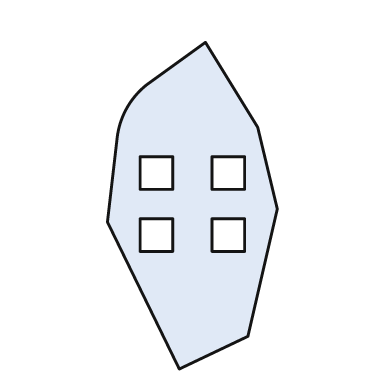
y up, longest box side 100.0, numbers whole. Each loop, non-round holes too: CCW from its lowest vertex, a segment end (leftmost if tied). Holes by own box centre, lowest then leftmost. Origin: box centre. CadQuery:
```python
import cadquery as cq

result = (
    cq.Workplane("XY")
    .moveTo(-4.0, -50.0)
    .lineTo(17.0, -40.0)
    .lineTo(26.0, -1.0)
    .lineTo(20.0, 24.0)
    .lineTo(4.0, 50.0)
    .lineTo(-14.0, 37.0)
    .threePointArc((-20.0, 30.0), (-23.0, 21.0))
    .lineTo(-26.0, -5.0)
    .close()
    .moveTo(-16.0, -14.0)
    .lineTo(-6.0, -14.0)
    .lineTo(-6.0, -4.0)
    .lineTo(-16.0, -4.0)
    .close()
    .moveTo(6.0, -14.0)
    .lineTo(16.0, -14.0)
    .lineTo(16.0, -4.0)
    .lineTo(6.0, -4.0)
    .close()
    .moveTo(-16.0, 5.0)
    .lineTo(-6.0, 5.0)
    .lineTo(-6.0, 15.0)
    .lineTo(-16.0, 15.0)
    .close()
    .moveTo(6.0, 5.0)
    .lineTo(16.0, 5.0)
    .lineTo(16.0, 15.0)
    .lineTo(6.0, 15.0)
    .close()
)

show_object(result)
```